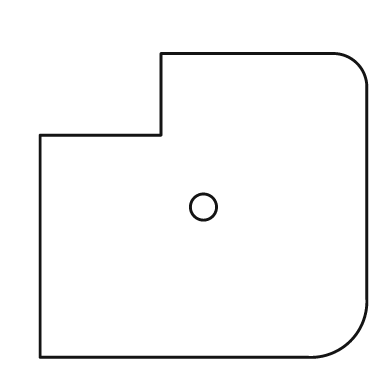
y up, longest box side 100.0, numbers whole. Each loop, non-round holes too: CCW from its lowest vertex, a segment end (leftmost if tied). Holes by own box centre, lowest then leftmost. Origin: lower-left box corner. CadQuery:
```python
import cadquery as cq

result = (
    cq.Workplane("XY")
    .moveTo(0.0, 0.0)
    .lineTo(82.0, 0.0)
    .threePointArc((95.0, 5.0), (100.0, 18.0))
    .lineTo(100.0, 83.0)
    .threePointArc((97.0, 90.0), (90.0, 93.0))
    .lineTo(37.0, 93.0)
    .lineTo(37.0, 68.0)
    .lineTo(0.0, 68.0)
    .close()
    .moveTo(50.0, 46.0)
    .circle(4.0)
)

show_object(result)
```